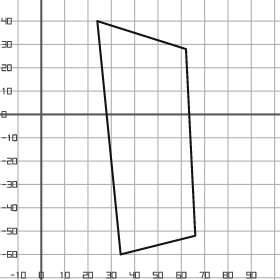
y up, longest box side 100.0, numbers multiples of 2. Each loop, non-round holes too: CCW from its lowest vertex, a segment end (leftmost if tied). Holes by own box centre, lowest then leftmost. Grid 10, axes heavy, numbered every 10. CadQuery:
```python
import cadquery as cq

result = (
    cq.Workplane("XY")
    .moveTo(34.0, -60.0)
    .lineTo(66.0, -52.0)
    .lineTo(62.0, 28.0)
    .lineTo(24.0, 40.0)
    .close()
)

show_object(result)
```